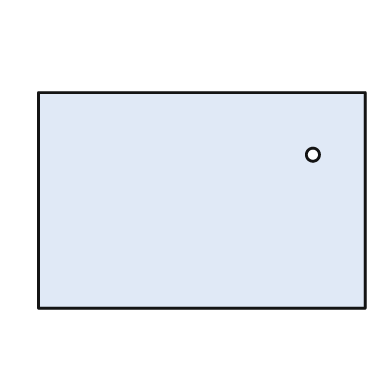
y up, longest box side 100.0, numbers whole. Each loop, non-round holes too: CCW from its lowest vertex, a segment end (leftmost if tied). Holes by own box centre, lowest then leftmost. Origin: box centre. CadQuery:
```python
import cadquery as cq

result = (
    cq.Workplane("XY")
    .moveTo(-50.0, -33.0)
    .lineTo(50.0, -33.0)
    .lineTo(50.0, 33.0)
    .lineTo(-50.0, 33.0)
    .close()
    .moveTo(34.0, 14.0)
    .circle(2.0)
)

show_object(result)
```